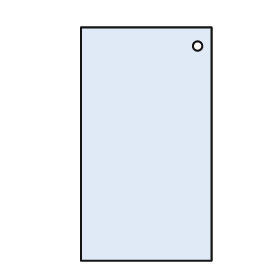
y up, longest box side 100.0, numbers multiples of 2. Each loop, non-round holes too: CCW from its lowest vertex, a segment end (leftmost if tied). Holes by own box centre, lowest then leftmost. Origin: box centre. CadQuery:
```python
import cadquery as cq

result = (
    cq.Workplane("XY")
    .moveTo(-28.0, -50.0)
    .lineTo(28.0, -50.0)
    .lineTo(28.0, 50.0)
    .lineTo(-28.0, 50.0)
    .close()
    .moveTo(22.0, 42.0)
    .circle(2.0)
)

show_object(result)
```